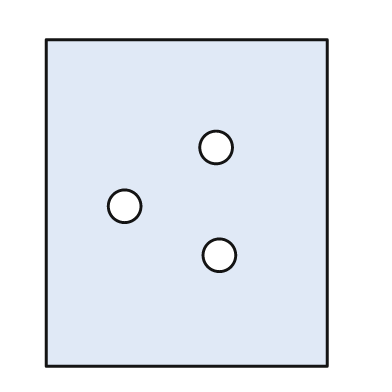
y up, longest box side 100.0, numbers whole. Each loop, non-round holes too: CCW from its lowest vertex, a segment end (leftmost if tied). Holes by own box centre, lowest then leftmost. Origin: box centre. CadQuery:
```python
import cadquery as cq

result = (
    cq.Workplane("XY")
    .moveTo(-43.0, -50.0)
    .lineTo(43.0, -50.0)
    .lineTo(43.0, 50.0)
    .lineTo(-43.0, 50.0)
    .close()
    .moveTo(10.0, -16.0)
    .circle(5.0)
    .moveTo(-19.0, -1.0)
    .circle(5.0)
    .moveTo(9.0, 17.0)
    .circle(5.0)
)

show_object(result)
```